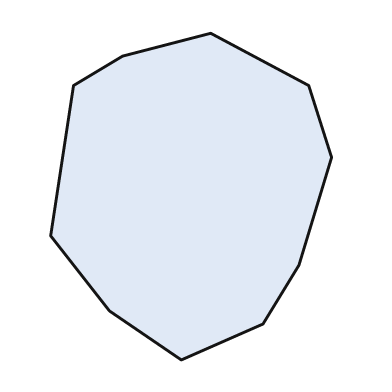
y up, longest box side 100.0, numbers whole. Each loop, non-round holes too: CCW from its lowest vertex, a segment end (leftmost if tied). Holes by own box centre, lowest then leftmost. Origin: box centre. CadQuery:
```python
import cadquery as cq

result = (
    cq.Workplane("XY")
    .moveTo(-3.0, -50.0)
    .lineTo(22.0, -39.0)
    .lineTo(33.0, -21.0)
    .lineTo(43.0, 12.0)
    .lineTo(36.0, 34.0)
    .lineTo(6.0, 50.0)
    .lineTo(-21.0, 43.0)
    .lineTo(-36.0, 34.0)
    .lineTo(-43.0, -12.0)
    .lineTo(-25.0, -35.0)
    .close()
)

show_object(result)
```